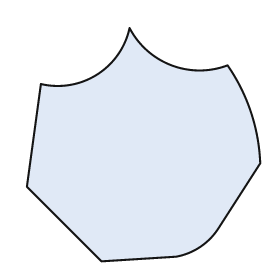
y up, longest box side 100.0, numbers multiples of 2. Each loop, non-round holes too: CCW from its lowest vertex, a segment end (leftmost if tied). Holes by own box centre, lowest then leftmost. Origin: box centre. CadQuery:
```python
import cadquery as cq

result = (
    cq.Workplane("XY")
    .moveTo(-18.0, -50.0)
    .lineTo(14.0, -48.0)
    .threePointArc((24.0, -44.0), (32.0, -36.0))
    .lineTo(50.0, -8.0)
    .threePointArc((46.0, 14.0), (36.0, 34.0))
    .threePointArc((12.0, 34.0), (-6.0, 50.0))
    .threePointArc((-20.0, 30.0), (-44.0, 26.0))
    .lineTo(-50.0, -18.0)
    .close()
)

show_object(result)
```